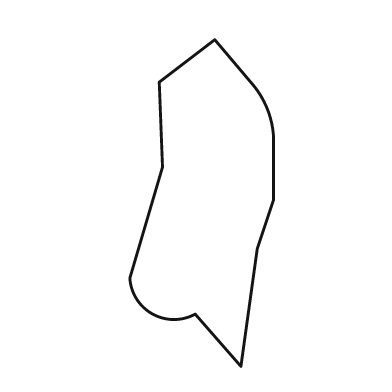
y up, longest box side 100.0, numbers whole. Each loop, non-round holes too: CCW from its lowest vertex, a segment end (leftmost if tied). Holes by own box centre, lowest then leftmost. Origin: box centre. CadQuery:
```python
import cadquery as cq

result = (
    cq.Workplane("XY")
    .moveTo(12.0, -50.0)
    .lineTo(17.0, -14.0)
    .lineTo(22.0, 1.0)
    .lineTo(22.0, 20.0)
    .threePointArc((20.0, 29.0), (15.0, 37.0))
    .lineTo(4.0, 50.0)
    .lineTo(-13.0, 37.0)
    .lineTo(-12.0, 11.0)
    .lineTo(-22.0, -23.0)
    .threePointArc((-15.0, -34.0), (-2.0, -34.0))
    .close()
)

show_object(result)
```